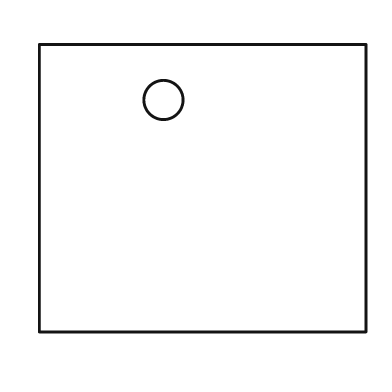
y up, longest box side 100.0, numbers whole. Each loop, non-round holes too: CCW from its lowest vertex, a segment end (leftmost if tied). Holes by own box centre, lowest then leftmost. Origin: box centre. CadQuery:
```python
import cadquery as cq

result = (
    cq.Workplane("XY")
    .moveTo(-50.0, -44.0)
    .lineTo(50.0, -44.0)
    .lineTo(50.0, 44.0)
    .lineTo(-50.0, 44.0)
    .close()
    .moveTo(-12.0, 27.0)
    .circle(6.0)
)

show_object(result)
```